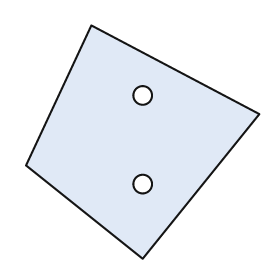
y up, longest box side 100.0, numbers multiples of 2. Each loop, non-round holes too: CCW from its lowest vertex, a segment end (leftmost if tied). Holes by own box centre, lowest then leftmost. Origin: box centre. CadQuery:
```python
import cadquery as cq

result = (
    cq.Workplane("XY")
    .moveTo(0.0, -50.0)
    .lineTo(50.0, 12.0)
    .lineTo(-22.0, 50.0)
    .lineTo(-50.0, -10.0)
    .close()
    .moveTo(0.0, -18.0)
    .circle(4.0)
    .moveTo(0.0, 20.0)
    .circle(4.0)
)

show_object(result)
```